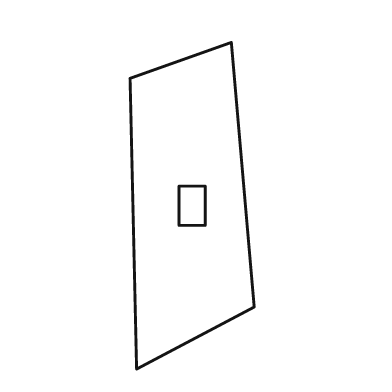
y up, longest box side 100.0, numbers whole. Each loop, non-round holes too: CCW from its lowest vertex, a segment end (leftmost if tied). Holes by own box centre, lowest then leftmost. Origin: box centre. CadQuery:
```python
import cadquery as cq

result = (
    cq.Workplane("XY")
    .moveTo(-17.0, -50.0)
    .lineTo(19.0, -31.0)
    .lineTo(12.0, 50.0)
    .lineTo(-19.0, 39.0)
    .close()
    .moveTo(-4.0, -6.0)
    .lineTo(4.0, -6.0)
    .lineTo(4.0, 6.0)
    .lineTo(-4.0, 6.0)
    .close()
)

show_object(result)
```